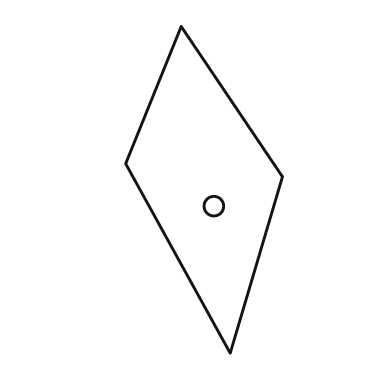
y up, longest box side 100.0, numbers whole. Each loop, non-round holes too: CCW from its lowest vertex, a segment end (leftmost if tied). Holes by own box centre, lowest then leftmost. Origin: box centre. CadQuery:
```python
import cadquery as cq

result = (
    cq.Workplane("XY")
    .moveTo(8.0, -50.0)
    .lineTo(24.0, 4.0)
    .lineTo(-7.0, 50.0)
    .lineTo(-24.0, 8.0)
    .close()
    .moveTo(3.0, -5.0)
    .circle(3.0)
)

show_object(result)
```